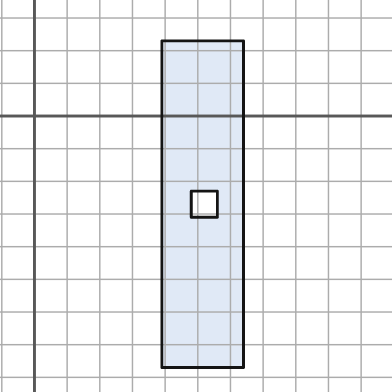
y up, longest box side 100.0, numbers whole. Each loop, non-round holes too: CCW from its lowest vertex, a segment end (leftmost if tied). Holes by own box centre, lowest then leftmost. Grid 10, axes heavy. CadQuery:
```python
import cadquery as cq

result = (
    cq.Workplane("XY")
    .moveTo(39.0, -77.0)
    .lineTo(64.0, -77.0)
    .lineTo(64.0, 23.0)
    .lineTo(39.0, 23.0)
    .close()
    .moveTo(48.0, -31.0)
    .lineTo(56.0, -31.0)
    .lineTo(56.0, -23.0)
    .lineTo(48.0, -23.0)
    .close()
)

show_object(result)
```